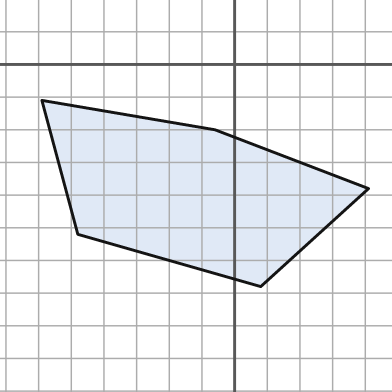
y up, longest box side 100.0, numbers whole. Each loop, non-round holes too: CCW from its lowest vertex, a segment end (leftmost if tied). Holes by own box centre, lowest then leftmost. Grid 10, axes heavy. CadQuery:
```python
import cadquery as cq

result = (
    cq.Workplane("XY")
    .moveTo(8.0, -68.0)
    .lineTo(41.0, -38.0)
    .lineTo(-6.0, -20.0)
    .lineTo(-59.0, -11.0)
    .lineTo(-48.0, -52.0)
    .close()
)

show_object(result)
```